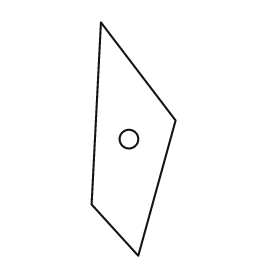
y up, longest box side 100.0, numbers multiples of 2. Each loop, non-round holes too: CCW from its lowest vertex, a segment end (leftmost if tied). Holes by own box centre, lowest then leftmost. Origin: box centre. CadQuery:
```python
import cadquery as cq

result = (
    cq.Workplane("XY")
    .moveTo(2.0, -50.0)
    .lineTo(18.0, 8.0)
    .lineTo(-14.0, 50.0)
    .lineTo(-18.0, -28.0)
    .close()
    .moveTo(-2.0, 0.0)
    .circle(4.0)
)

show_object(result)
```